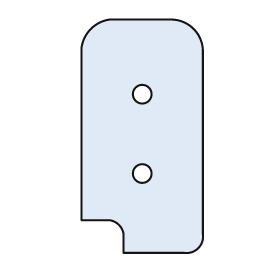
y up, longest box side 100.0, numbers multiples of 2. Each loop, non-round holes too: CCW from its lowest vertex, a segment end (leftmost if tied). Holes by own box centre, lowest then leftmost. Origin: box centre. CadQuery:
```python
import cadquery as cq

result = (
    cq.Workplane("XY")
    .moveTo(-8.0, -50.0)
    .lineTo(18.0, -50.0)
    .threePointArc((24.0, -48.0), (26.0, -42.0))
    .lineTo(26.0, 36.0)
    .threePointArc((22.0, 46.0), (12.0, 50.0))
    .lineTo(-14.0, 50.0)
    .threePointArc((-22.0, 46.0), (-26.0, 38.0))
    .lineTo(-26.0, -36.0)
    .lineTo(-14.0, -36.0)
    .threePointArc((-10.0, -38.0), (-8.0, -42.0))
    .close()
    .moveTo(0.0, -16.0)
    .circle(4.0)
    .moveTo(0.0, 18.0)
    .circle(4.0)
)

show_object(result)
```